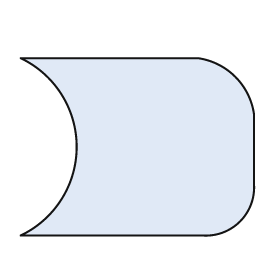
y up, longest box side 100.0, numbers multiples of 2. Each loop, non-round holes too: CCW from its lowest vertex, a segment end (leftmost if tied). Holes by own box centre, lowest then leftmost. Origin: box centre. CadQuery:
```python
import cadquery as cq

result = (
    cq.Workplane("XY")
    .moveTo(-50.0, -38.0)
    .lineTo(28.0, -38.0)
    .threePointArc((44.0, -32.0), (50.0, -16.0))
    .lineTo(50.0, 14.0)
    .threePointArc((42.0, 30.0), (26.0, 38.0))
    .lineTo(-50.0, 38.0)
    .threePointArc((-26.0, 0.0), (-50.0, -38.0))
    .close()
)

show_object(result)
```